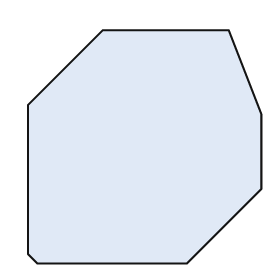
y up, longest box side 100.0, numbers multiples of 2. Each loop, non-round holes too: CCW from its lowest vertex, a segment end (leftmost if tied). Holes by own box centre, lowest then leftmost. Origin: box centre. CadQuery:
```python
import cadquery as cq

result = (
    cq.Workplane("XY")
    .moveTo(-46.0, -50.0)
    .lineTo(18.0, -50.0)
    .lineTo(50.0, -18.0)
    .lineTo(50.0, 14.0)
    .lineTo(36.0, 50.0)
    .lineTo(-18.0, 50.0)
    .lineTo(-50.0, 18.0)
    .lineTo(-50.0, -46.0)
    .close()
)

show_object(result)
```